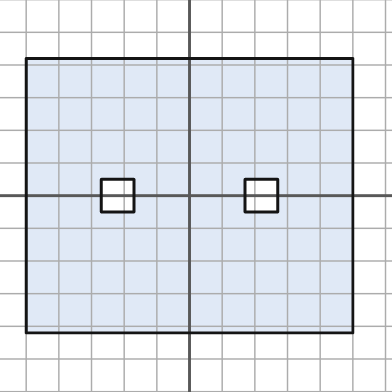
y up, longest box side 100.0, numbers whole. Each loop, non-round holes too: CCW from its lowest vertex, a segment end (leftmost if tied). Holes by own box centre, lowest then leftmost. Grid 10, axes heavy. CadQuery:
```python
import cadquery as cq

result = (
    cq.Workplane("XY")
    .moveTo(-50.0, -42.0)
    .lineTo(50.0, -42.0)
    .lineTo(50.0, 42.0)
    .lineTo(-50.0, 42.0)
    .close()
    .moveTo(-27.0, -5.0)
    .lineTo(-17.0, -5.0)
    .lineTo(-17.0, 5.0)
    .lineTo(-27.0, 5.0)
    .close()
    .moveTo(17.0, -5.0)
    .lineTo(27.0, -5.0)
    .lineTo(27.0, 5.0)
    .lineTo(17.0, 5.0)
    .close()
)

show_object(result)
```